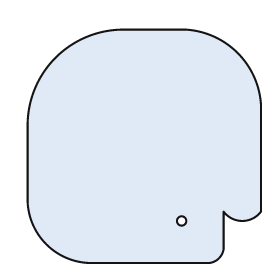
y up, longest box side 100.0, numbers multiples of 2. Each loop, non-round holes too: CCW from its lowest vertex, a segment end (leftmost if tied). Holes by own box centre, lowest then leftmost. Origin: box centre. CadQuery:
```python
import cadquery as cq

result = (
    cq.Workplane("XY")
    .moveTo(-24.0, -50.0)
    .lineTo(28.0, -50.0)
    .threePointArc((32.0, -48.0), (34.0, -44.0))
    .lineTo(34.0, -28.0)
    .threePointArc((42.0, -32.0), (50.0, -28.0))
    .lineTo(50.0, 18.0)
    .threePointArc((40.0, 40.0), (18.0, 50.0))
    .lineTo(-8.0, 50.0)
    .threePointArc((-38.0, 38.0), (-50.0, 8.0))
    .lineTo(-50.0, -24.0)
    .threePointArc((-42.0, -42.0), (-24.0, -50.0))
    .close()
    .moveTo(16.0, -32.0)
    .circle(2.0)
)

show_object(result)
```